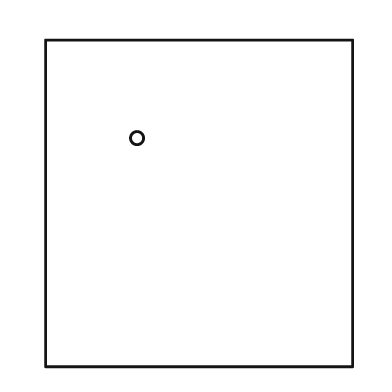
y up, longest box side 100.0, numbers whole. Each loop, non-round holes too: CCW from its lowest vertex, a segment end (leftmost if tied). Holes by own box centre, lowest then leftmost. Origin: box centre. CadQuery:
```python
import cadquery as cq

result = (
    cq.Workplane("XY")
    .moveTo(-47.0, -50.0)
    .lineTo(47.0, -50.0)
    .lineTo(47.0, 50.0)
    .lineTo(-47.0, 50.0)
    .close()
    .moveTo(-19.0, 20.0)
    .circle(2.0)
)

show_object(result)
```